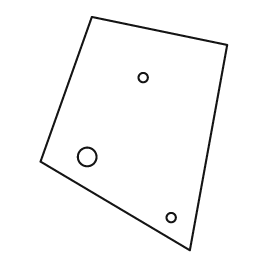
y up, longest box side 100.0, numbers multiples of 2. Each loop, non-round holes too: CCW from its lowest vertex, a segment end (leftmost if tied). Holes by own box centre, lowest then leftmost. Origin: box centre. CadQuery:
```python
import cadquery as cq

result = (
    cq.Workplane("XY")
    .moveTo(24.0, -50.0)
    .lineTo(40.0, 38.0)
    .lineTo(-18.0, 50.0)
    .lineTo(-40.0, -12.0)
    .close()
    .moveTo(16.0, -36.0)
    .circle(2.0)
    .moveTo(-20.0, -10.0)
    .circle(4.0)
    .moveTo(4.0, 24.0)
    .circle(2.0)
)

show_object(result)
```